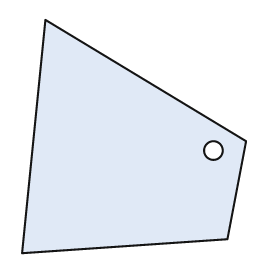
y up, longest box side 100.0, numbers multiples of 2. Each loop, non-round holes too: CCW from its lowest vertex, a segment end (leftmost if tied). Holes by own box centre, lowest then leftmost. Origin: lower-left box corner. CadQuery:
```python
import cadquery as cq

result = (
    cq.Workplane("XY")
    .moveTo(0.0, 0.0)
    .lineTo(88.0, 6.0)
    .lineTo(96.0, 48.0)
    .lineTo(10.0, 100.0)
    .close()
    .moveTo(82.0, 44.0)
    .circle(4.0)
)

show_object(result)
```